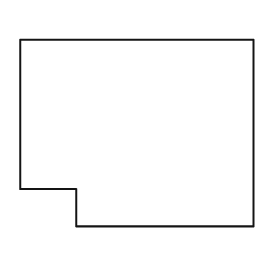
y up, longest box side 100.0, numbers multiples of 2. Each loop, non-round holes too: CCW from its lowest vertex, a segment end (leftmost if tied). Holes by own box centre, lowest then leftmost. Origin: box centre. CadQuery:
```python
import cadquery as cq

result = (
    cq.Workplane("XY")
    .moveTo(-26.0, -40.0)
    .lineTo(50.0, -40.0)
    .lineTo(50.0, 40.0)
    .lineTo(-50.0, 40.0)
    .lineTo(-50.0, -24.0)
    .lineTo(-26.0, -24.0)
    .close()
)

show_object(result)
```